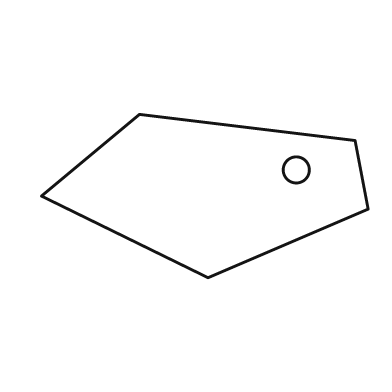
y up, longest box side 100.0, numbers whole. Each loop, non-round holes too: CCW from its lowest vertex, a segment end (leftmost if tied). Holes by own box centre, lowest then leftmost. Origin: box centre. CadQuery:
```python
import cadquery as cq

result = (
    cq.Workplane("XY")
    .moveTo(1.0, -25.0)
    .lineTo(50.0, -4.0)
    .lineTo(46.0, 17.0)
    .lineTo(-20.0, 25.0)
    .lineTo(-50.0, 0.0)
    .close()
    .moveTo(28.0, 8.0)
    .circle(4.0)
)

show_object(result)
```